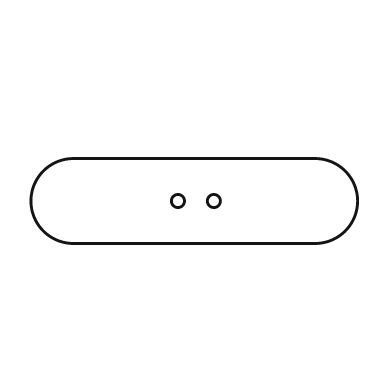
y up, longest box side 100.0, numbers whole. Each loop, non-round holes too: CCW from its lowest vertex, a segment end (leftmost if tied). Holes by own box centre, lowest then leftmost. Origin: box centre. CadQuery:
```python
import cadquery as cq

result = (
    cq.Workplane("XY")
    .moveTo(-37.0, -13.0)
    .lineTo(37.0, -13.0)
    .threePointArc((50.0, 0.0), (37.0, 13.0))
    .lineTo(-37.0, 13.0)
    .threePointArc((-50.0, 0.0), (-37.0, -13.0))
    .close()
    .moveTo(-5.0, 0.0)
    .circle(2.0)
    .moveTo(6.0, 0.0)
    .circle(2.0)
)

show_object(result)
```